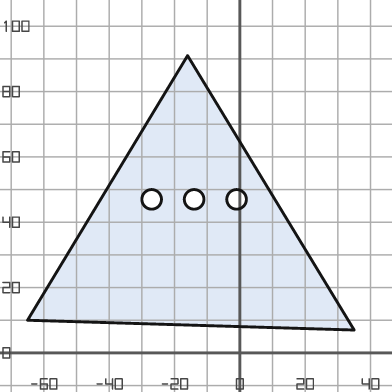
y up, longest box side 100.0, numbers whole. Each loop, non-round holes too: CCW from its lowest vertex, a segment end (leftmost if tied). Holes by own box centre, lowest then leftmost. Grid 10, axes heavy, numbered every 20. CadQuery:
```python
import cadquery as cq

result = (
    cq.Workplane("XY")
    .moveTo(35.0, 7.0)
    .lineTo(-16.0, 91.0)
    .lineTo(-65.0, 10.0)
    .close()
    .moveTo(-27.0, 47.0)
    .circle(3.0)
    .moveTo(-14.0, 47.0)
    .circle(3.0)
    .moveTo(-1.0, 47.0)
    .circle(3.0)
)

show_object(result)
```